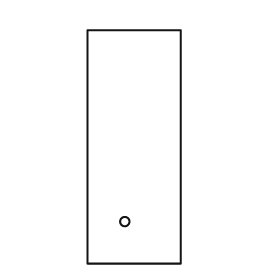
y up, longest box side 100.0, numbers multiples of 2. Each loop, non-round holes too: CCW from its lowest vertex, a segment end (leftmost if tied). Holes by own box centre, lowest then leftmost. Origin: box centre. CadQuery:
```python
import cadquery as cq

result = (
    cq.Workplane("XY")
    .moveTo(-20.0, -50.0)
    .lineTo(20.0, -50.0)
    .lineTo(20.0, 50.0)
    .lineTo(-20.0, 50.0)
    .close()
    .moveTo(-4.0, -32.0)
    .circle(2.0)
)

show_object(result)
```